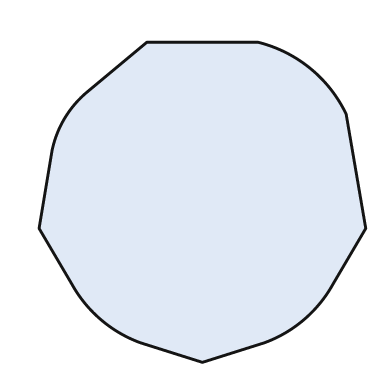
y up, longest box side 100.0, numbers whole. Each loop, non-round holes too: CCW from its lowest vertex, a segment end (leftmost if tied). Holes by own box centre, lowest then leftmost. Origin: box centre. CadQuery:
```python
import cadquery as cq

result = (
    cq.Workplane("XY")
    .moveTo(0.0, -49.0)
    .lineTo(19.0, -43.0)
    .threePointArc((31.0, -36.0), (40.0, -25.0))
    .lineTo(50.0, -8.0)
    .lineTo(44.0, 27.0)
    .threePointArc((33.0, 41.0), (17.0, 49.0))
    .lineTo(-17.0, 49.0)
    .lineTo(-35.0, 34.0)
    .threePointArc((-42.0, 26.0), (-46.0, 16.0))
    .lineTo(-50.0, -8.0)
    .lineTo(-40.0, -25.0)
    .threePointArc((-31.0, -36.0), (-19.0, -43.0))
    .close()
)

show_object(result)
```